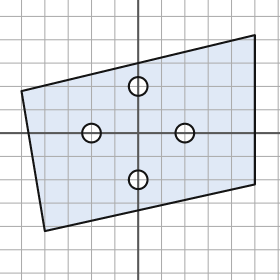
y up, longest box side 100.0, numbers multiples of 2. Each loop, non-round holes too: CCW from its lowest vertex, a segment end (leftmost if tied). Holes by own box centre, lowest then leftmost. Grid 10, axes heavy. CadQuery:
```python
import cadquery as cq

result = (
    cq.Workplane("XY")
    .moveTo(-40.0, -42.0)
    .lineTo(50.0, -22.0)
    .lineTo(50.0, 42.0)
    .lineTo(-50.0, 18.0)
    .close()
    .moveTo(0.0, -20.0)
    .circle(4.0)
    .moveTo(-20.0, 0.0)
    .circle(4.0)
    .moveTo(20.0, 0.0)
    .circle(4.0)
    .moveTo(0.0, 20.0)
    .circle(4.0)
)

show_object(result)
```